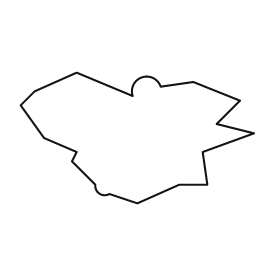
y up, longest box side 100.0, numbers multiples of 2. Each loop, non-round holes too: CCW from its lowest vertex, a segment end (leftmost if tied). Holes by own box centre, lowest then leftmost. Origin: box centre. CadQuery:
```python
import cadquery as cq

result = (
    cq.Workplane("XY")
    .moveTo(0.0, -28.0)
    .lineTo(18.0, -20.0)
    .lineTo(30.0, -20.0)
    .lineTo(28.0, -6.0)
    .lineTo(50.0, 2.0)
    .lineTo(34.0, 6.0)
    .lineTo(44.0, 16.0)
    .lineTo(24.0, 24.0)
    .lineTo(10.0, 22.0)
    .threePointArc((2.0, 26.0), (-2.0, 18.0))
    .lineTo(-26.0, 28.0)
    .lineTo(-44.0, 20.0)
    .lineTo(-50.0, 14.0)
    .lineTo(-40.0, 0.0)
    .lineTo(-26.0, -6.0)
    .lineTo(-28.0, -10.0)
    .lineTo(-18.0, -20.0)
    .threePointArc((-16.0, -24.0), (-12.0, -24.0))
    .close()
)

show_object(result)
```